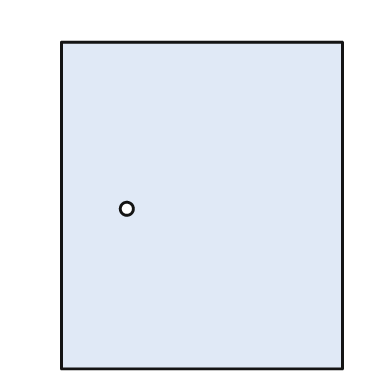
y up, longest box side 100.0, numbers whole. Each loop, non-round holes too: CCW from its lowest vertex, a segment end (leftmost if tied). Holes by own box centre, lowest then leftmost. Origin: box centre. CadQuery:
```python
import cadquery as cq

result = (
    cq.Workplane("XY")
    .moveTo(-43.0, -50.0)
    .lineTo(43.0, -50.0)
    .lineTo(43.0, 50.0)
    .lineTo(-43.0, 50.0)
    .close()
    .moveTo(-23.0, -1.0)
    .circle(2.0)
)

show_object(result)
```